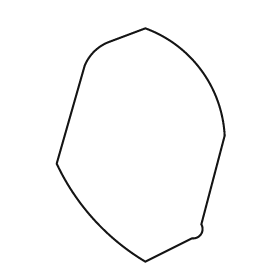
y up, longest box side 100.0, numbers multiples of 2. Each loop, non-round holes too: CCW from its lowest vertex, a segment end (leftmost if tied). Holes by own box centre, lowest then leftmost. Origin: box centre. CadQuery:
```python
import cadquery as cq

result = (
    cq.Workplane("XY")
    .moveTo(2.0, -50.0)
    .lineTo(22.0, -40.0)
    .threePointArc((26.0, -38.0), (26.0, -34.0))
    .lineTo(36.0, 4.0)
    .threePointArc((26.0, 32.0), (2.0, 50.0))
    .lineTo(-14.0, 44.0)
    .threePointArc((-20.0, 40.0), (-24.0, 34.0))
    .lineTo(-36.0, -8.0)
    .threePointArc((-20.0, -32.0), (2.0, -50.0))
    .close()
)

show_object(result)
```